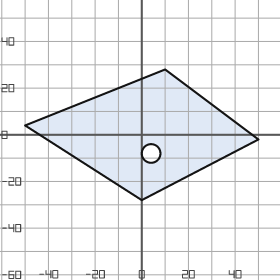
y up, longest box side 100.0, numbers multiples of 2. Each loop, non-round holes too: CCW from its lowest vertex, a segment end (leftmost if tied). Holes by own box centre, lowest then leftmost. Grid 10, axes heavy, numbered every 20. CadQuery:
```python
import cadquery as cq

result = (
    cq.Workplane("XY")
    .moveTo(0.0, -28.0)
    .lineTo(50.0, -2.0)
    .lineTo(10.0, 28.0)
    .lineTo(-50.0, 4.0)
    .close()
    .moveTo(4.0, -8.0)
    .circle(4.0)
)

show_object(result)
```